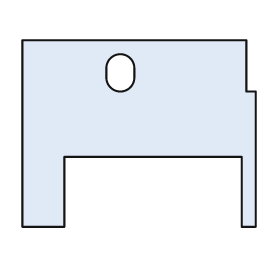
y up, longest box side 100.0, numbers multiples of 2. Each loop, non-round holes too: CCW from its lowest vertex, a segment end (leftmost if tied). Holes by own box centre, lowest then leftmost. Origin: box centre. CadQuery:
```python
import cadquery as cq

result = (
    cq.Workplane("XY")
    .moveTo(-50.0, -40.0)
    .lineTo(-32.0, -40.0)
    .lineTo(-32.0, -10.0)
    .lineTo(44.0, -10.0)
    .lineTo(44.0, -40.0)
    .lineTo(50.0, -40.0)
    .lineTo(50.0, 18.0)
    .lineTo(46.0, 18.0)
    .lineTo(46.0, 40.0)
    .lineTo(-50.0, 40.0)
    .close()
    .moveTo(-14.0, 24.0)
    .threePointArc((-8.0, 18.0), (-2.0, 24.0))
    .lineTo(-2.0, 28.0)
    .threePointArc((-8.0, 34.0), (-14.0, 28.0))
    .close()
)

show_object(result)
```